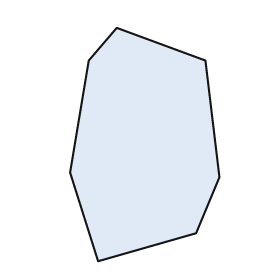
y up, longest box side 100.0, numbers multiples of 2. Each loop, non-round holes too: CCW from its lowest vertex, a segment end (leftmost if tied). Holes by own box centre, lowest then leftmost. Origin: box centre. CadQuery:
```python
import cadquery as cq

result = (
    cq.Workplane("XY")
    .moveTo(-20.0, -50.0)
    .lineTo(22.0, -38.0)
    .lineTo(32.0, -14.0)
    .lineTo(26.0, 36.0)
    .lineTo(-12.0, 50.0)
    .lineTo(-24.0, 36.0)
    .lineTo(-32.0, -12.0)
    .close()
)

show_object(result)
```